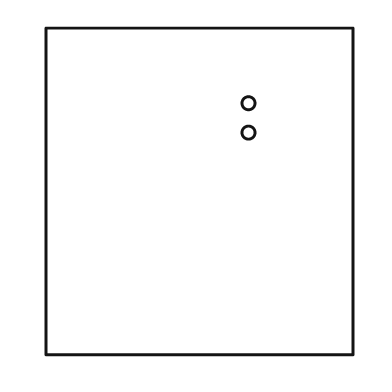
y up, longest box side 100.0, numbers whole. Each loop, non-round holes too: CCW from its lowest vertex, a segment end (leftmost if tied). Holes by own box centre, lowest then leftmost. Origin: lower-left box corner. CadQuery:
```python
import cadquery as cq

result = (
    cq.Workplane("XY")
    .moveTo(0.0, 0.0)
    .lineTo(94.0, 0.0)
    .lineTo(94.0, 100.0)
    .lineTo(0.0, 100.0)
    .close()
    .moveTo(62.0, 68.0)
    .circle(2.0)
    .moveTo(62.0, 77.0)
    .circle(2.0)
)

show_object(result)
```